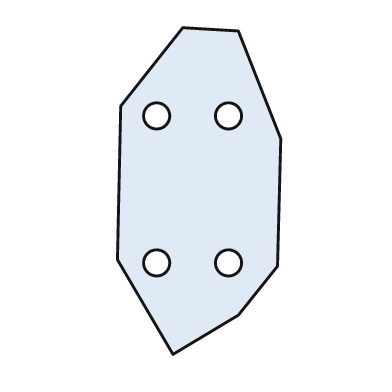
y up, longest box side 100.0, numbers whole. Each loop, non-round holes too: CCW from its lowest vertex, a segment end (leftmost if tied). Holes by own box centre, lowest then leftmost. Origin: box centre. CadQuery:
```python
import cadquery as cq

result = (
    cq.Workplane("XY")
    .moveTo(-8.0, -50.0)
    .lineTo(12.0, -38.0)
    .lineTo(24.0, -23.0)
    .lineTo(25.0, 16.0)
    .lineTo(12.0, 49.0)
    .lineTo(-5.0, 50.0)
    .lineTo(-24.0, 26.0)
    .lineTo(-25.0, -21.0)
    .close()
    .moveTo(-13.0, -22.0)
    .circle(4.0)
    .moveTo(9.0, -22.0)
    .circle(4.0)
    .moveTo(-13.0, 23.0)
    .circle(4.0)
    .moveTo(9.0, 23.0)
    .circle(4.0)
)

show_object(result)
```